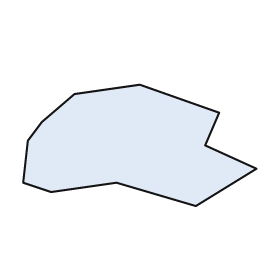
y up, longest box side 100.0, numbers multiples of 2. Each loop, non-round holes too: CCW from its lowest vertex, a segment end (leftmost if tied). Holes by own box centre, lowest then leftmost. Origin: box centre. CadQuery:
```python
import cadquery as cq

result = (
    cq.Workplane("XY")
    .moveTo(24.0, -26.0)
    .lineTo(50.0, -10.0)
    .lineTo(28.0, 0.0)
    .lineTo(34.0, 14.0)
    .lineTo(0.0, 26.0)
    .lineTo(-28.0, 22.0)
    .lineTo(-42.0, 10.0)
    .lineTo(-48.0, 2.0)
    .lineTo(-50.0, -16.0)
    .lineTo(-38.0, -20.0)
    .lineTo(-10.0, -16.0)
    .close()
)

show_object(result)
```